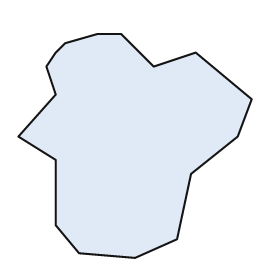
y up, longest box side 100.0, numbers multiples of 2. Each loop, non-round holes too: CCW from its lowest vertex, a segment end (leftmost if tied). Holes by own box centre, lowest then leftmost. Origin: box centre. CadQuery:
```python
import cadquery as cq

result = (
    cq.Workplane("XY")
    .moveTo(0.0, -48.0)
    .lineTo(18.0, -40.0)
    .lineTo(24.0, -12.0)
    .lineTo(44.0, 4.0)
    .lineTo(50.0, 20.0)
    .lineTo(26.0, 40.0)
    .lineTo(8.0, 34.0)
    .lineTo(-6.0, 48.0)
    .lineTo(-16.0, 48.0)
    .lineTo(-30.0, 44.0)
    .lineTo(-34.0, 40.0)
    .lineTo(-38.0, 34.0)
    .lineTo(-34.0, 22.0)
    .lineTo(-50.0, 4.0)
    .lineTo(-34.0, -6.0)
    .lineTo(-34.0, -34.0)
    .lineTo(-24.0, -46.0)
    .close()
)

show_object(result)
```